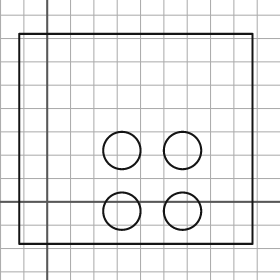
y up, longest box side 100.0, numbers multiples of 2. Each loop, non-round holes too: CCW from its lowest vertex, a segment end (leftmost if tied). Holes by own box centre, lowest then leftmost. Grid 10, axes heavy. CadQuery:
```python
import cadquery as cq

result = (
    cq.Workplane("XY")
    .moveTo(-12.0, -18.0)
    .lineTo(88.0, -18.0)
    .lineTo(88.0, 72.0)
    .lineTo(-12.0, 72.0)
    .close()
    .moveTo(32.0, -4.0)
    .circle(8.0)
    .moveTo(58.0, -4.0)
    .circle(8.0)
    .moveTo(32.0, 22.0)
    .circle(8.0)
    .moveTo(58.0, 22.0)
    .circle(8.0)
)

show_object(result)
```